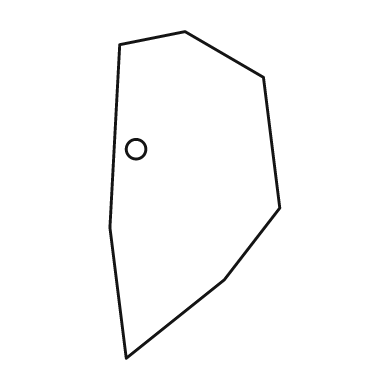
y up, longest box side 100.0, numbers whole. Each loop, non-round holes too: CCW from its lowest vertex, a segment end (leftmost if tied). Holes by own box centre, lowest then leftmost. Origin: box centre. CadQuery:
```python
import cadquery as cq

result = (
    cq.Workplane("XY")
    .moveTo(-21.0, -50.0)
    .lineTo(9.0, -26.0)
    .lineTo(26.0, -4.0)
    .lineTo(21.0, 36.0)
    .lineTo(-3.0, 50.0)
    .lineTo(-23.0, 46.0)
    .lineTo(-26.0, -10.0)
    .close()
    .moveTo(-18.0, 14.0)
    .circle(3.0)
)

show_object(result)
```